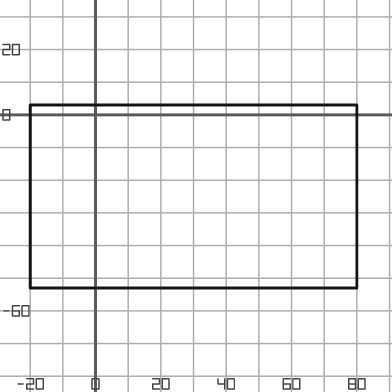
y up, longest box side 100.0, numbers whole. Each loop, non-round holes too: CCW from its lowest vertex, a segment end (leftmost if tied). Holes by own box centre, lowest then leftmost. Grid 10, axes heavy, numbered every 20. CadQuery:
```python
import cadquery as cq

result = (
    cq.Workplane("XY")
    .moveTo(-20.0, -53.0)
    .lineTo(80.0, -53.0)
    .lineTo(80.0, 3.0)
    .lineTo(-20.0, 3.0)
    .close()
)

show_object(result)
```